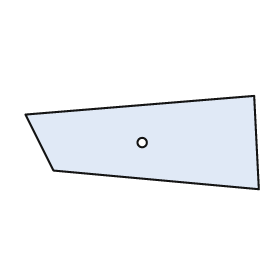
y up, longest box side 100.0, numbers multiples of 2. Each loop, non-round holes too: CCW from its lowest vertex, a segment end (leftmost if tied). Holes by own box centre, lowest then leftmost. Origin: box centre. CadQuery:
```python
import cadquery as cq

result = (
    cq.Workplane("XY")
    .moveTo(50.0, -20.0)
    .lineTo(48.0, 20.0)
    .lineTo(-50.0, 12.0)
    .lineTo(-38.0, -12.0)
    .close()
    .moveTo(0.0, 0.0)
    .circle(2.0)
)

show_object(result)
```